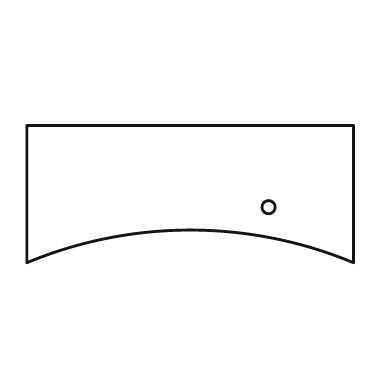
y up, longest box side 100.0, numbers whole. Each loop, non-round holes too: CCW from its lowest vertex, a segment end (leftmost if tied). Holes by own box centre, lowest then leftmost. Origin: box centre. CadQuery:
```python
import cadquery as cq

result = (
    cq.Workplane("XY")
    .moveTo(-50.0, -21.0)
    .threePointArc((0.0, -11.0), (50.0, -21.0))
    .lineTo(50.0, 21.0)
    .lineTo(-50.0, 21.0)
    .close()
    .moveTo(24.0, -4.0)
    .circle(2.0)
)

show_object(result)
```